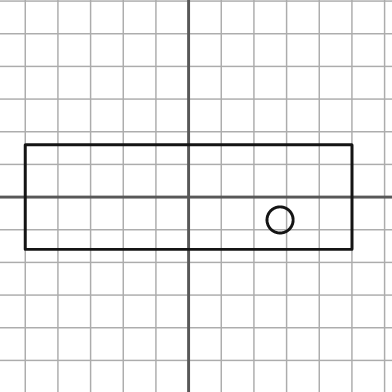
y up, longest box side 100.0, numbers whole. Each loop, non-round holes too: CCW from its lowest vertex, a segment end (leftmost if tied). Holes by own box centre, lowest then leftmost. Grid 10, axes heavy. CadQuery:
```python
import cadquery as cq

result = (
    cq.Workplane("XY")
    .moveTo(-50.0, -16.0)
    .lineTo(50.0, -16.0)
    .lineTo(50.0, 16.0)
    .lineTo(-50.0, 16.0)
    .close()
    .moveTo(28.0, -7.0)
    .circle(4.0)
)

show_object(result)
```